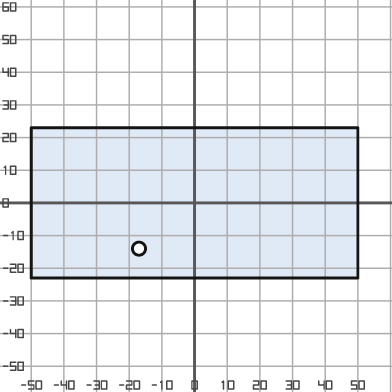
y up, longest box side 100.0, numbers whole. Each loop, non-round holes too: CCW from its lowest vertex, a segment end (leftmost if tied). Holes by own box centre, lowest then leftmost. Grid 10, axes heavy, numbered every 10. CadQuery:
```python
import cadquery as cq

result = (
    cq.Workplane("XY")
    .moveTo(-50.0, -23.0)
    .lineTo(50.0, -23.0)
    .lineTo(50.0, 23.0)
    .lineTo(-50.0, 23.0)
    .close()
    .moveTo(-17.0, -14.0)
    .circle(2.0)
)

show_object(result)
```